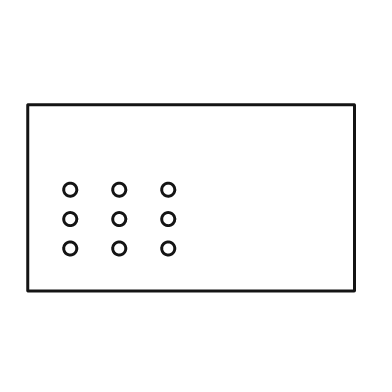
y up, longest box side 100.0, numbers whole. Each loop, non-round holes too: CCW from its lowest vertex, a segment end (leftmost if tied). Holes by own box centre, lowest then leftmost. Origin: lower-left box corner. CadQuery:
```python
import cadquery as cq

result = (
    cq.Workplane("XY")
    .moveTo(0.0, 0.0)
    .lineTo(100.0, 0.0)
    .lineTo(100.0, 57.0)
    .lineTo(0.0, 57.0)
    .close()
    .moveTo(13.0, 13.0)
    .circle(2.0)
    .moveTo(28.0, 13.0)
    .circle(2.0)
    .moveTo(43.0, 13.0)
    .circle(2.0)
    .moveTo(13.0, 22.0)
    .circle(2.0)
    .moveTo(28.0, 22.0)
    .circle(2.0)
    .moveTo(43.0, 22.0)
    .circle(2.0)
    .moveTo(13.0, 31.0)
    .circle(2.0)
    .moveTo(28.0, 31.0)
    .circle(2.0)
    .moveTo(43.0, 31.0)
    .circle(2.0)
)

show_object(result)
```